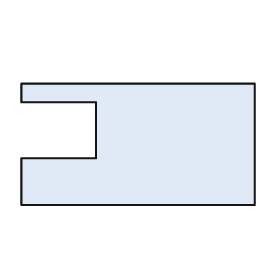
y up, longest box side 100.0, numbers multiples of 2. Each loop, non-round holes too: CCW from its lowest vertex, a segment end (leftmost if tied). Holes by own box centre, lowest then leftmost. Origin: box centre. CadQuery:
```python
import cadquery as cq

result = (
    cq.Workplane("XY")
    .moveTo(-50.0, -26.0)
    .lineTo(50.0, -26.0)
    .lineTo(50.0, 26.0)
    .lineTo(-50.0, 26.0)
    .lineTo(-50.0, 18.0)
    .lineTo(-18.0, 18.0)
    .lineTo(-18.0, -6.0)
    .lineTo(-50.0, -6.0)
    .close()
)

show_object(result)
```